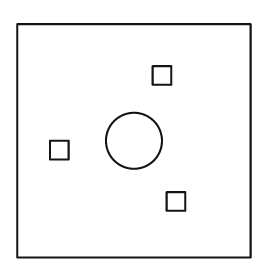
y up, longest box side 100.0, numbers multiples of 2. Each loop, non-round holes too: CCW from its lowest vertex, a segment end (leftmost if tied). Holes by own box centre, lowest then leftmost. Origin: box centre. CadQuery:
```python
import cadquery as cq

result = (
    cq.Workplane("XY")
    .moveTo(-50.0, -50.0)
    .lineTo(50.0, -50.0)
    .lineTo(50.0, 50.0)
    .lineTo(-50.0, 50.0)
    .close()
    .moveTo(14.0, -30.0)
    .lineTo(22.0, -30.0)
    .lineTo(22.0, -22.0)
    .lineTo(14.0, -22.0)
    .close()
    .moveTo(-36.0, -8.0)
    .lineTo(-28.0, -8.0)
    .lineTo(-28.0, 0.0)
    .lineTo(-36.0, 0.0)
    .close()
    .moveTo(0.0, 0.0)
    .circle(12.0)
    .moveTo(8.0, 24.0)
    .lineTo(16.0, 24.0)
    .lineTo(16.0, 32.0)
    .lineTo(8.0, 32.0)
    .close()
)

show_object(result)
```